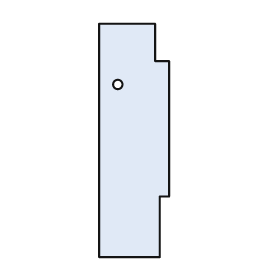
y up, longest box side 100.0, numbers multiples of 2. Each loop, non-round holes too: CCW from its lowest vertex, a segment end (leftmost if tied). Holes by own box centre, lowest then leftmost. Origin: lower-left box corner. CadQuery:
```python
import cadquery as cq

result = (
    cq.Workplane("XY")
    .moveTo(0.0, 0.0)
    .lineTo(26.0, 0.0)
    .lineTo(26.0, 26.0)
    .lineTo(30.0, 26.0)
    .lineTo(30.0, 84.0)
    .lineTo(24.0, 84.0)
    .lineTo(24.0, 100.0)
    .lineTo(0.0, 100.0)
    .close()
    .moveTo(8.0, 74.0)
    .circle(2.0)
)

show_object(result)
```